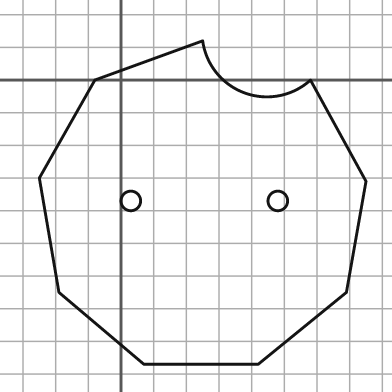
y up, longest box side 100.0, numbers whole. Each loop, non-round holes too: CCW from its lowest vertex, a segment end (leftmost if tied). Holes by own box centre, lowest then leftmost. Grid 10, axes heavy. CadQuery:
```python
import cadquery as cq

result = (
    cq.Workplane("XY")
    .moveTo(7.0, -87.0)
    .lineTo(42.0, -87.0)
    .lineTo(69.0, -65.0)
    .lineTo(75.0, -31.0)
    .lineTo(58.0, 0.0)
    .threePointArc((38.0, -4.0), (25.0, 12.0))
    .lineTo(-8.0, 0.0)
    .lineTo(-25.0, -30.0)
    .lineTo(-19.0, -65.0)
    .close()
    .moveTo(3.0, -37.0)
    .circle(3.0)
    .moveTo(48.0, -37.0)
    .circle(3.0)
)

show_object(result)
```